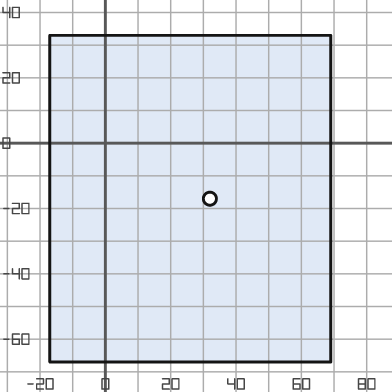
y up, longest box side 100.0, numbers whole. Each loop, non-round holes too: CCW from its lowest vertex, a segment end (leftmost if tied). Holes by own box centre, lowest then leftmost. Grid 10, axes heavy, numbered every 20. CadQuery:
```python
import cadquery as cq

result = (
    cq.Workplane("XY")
    .moveTo(-17.0, -67.0)
    .lineTo(69.0, -67.0)
    .lineTo(69.0, 33.0)
    .lineTo(-17.0, 33.0)
    .close()
    .moveTo(32.0, -17.0)
    .circle(2.0)
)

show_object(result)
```